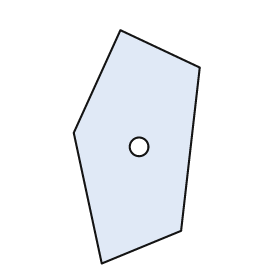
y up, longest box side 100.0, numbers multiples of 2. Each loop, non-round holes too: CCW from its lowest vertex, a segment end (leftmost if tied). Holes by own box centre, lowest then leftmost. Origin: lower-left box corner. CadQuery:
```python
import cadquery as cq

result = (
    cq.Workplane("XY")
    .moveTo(12.0, 0.0)
    .lineTo(46.0, 14.0)
    .lineTo(54.0, 84.0)
    .lineTo(20.0, 100.0)
    .lineTo(0.0, 56.0)
    .close()
    .moveTo(28.0, 50.0)
    .circle(4.0)
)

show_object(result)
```